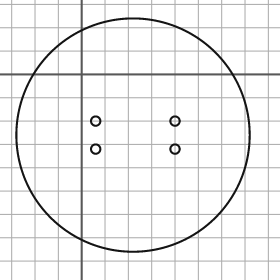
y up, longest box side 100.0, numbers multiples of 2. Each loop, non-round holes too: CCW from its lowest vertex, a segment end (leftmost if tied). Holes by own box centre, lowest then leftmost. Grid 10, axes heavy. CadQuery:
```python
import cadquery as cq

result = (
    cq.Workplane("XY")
    .moveTo(22.0, -26.0)
    .circle(50.0)
    .moveTo(6.0, -32.0)
    .circle(2.0)
    .moveTo(40.0, -32.0)
    .circle(2.0)
    .moveTo(6.0, -20.0)
    .circle(2.0)
    .moveTo(40.0, -20.0)
    .circle(2.0)
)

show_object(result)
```